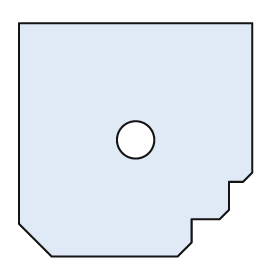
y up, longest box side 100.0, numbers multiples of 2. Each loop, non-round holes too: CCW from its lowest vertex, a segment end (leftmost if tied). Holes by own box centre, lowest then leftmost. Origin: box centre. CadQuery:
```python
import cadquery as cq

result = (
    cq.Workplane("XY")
    .moveTo(-36.0, -50.0)
    .lineTo(18.0, -50.0)
    .lineTo(24.0, -44.0)
    .lineTo(24.0, -34.0)
    .lineTo(36.0, -34.0)
    .lineTo(40.0, -30.0)
    .lineTo(40.0, -18.0)
    .lineTo(46.0, -18.0)
    .lineTo(50.0, -14.0)
    .lineTo(50.0, 50.0)
    .lineTo(-50.0, 50.0)
    .lineTo(-50.0, -36.0)
    .close()
    .moveTo(0.0, 0.0)
    .circle(8.0)
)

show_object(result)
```